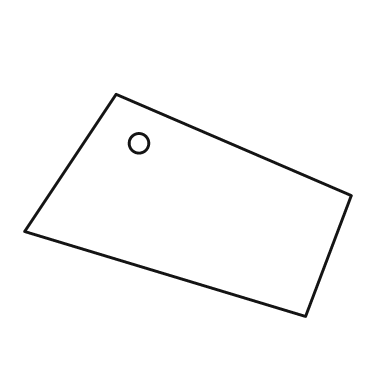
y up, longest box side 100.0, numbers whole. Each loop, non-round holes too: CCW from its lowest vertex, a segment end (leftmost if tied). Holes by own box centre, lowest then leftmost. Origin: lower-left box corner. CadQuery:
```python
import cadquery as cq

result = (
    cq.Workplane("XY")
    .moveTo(86.0, 0.0)
    .lineTo(100.0, 37.0)
    .lineTo(28.0, 68.0)
    .lineTo(0.0, 26.0)
    .close()
    .moveTo(35.0, 53.0)
    .circle(3.0)
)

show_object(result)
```